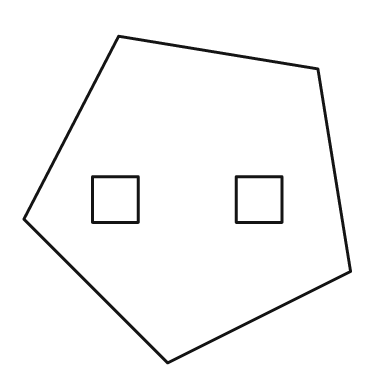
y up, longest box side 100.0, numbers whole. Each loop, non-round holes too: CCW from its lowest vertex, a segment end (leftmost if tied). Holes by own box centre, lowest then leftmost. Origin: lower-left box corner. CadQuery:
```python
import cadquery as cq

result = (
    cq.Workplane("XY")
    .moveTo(44.0, 0.0)
    .lineTo(100.0, 28.0)
    .lineTo(90.0, 90.0)
    .lineTo(29.0, 100.0)
    .lineTo(0.0, 44.0)
    .close()
    .moveTo(21.0, 43.0)
    .lineTo(35.0, 43.0)
    .lineTo(35.0, 57.0)
    .lineTo(21.0, 57.0)
    .close()
    .moveTo(65.0, 43.0)
    .lineTo(79.0, 43.0)
    .lineTo(79.0, 57.0)
    .lineTo(65.0, 57.0)
    .close()
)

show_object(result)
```